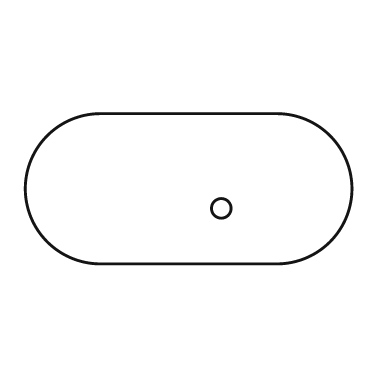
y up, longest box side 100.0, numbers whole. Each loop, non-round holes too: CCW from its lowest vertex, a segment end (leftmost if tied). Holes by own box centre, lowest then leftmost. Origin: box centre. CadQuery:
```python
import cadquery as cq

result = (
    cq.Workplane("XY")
    .moveTo(-27.0, -23.0)
    .lineTo(27.0, -23.0)
    .threePointArc((50.0, 0.0), (27.0, 23.0))
    .lineTo(-27.0, 23.0)
    .threePointArc((-50.0, 0.0), (-27.0, -23.0))
    .close()
    .moveTo(10.0, -6.0)
    .circle(3.0)
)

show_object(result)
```